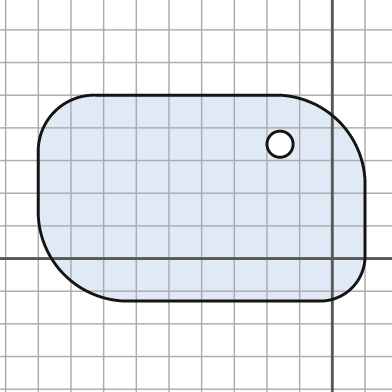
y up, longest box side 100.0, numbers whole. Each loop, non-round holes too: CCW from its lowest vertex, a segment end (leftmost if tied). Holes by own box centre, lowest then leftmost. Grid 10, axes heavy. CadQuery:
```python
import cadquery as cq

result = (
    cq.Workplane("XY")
    .moveTo(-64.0, -13.0)
    .lineTo(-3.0, -13.0)
    .threePointArc((6.0, -9.0), (10.0, 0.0))
    .lineTo(10.0, 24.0)
    .threePointArc((2.0, 42.0), (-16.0, 50.0))
    .lineTo(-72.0, 50.0)
    .threePointArc((-85.0, 45.0), (-90.0, 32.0))
    .lineTo(-90.0, 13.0)
    .threePointArc((-82.0, -5.0), (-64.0, -13.0))
    .close()
    .moveTo(-16.0, 35.0)
    .circle(4.0)
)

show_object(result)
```